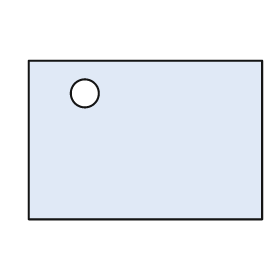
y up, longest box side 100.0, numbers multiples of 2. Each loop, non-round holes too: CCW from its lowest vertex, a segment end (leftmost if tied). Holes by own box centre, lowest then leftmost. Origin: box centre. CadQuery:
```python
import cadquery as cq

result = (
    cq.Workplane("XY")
    .moveTo(-50.0, -34.0)
    .lineTo(50.0, -34.0)
    .lineTo(50.0, 34.0)
    .lineTo(-50.0, 34.0)
    .close()
    .moveTo(-26.0, 20.0)
    .circle(6.0)
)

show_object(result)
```